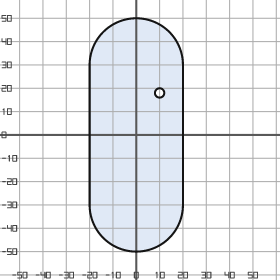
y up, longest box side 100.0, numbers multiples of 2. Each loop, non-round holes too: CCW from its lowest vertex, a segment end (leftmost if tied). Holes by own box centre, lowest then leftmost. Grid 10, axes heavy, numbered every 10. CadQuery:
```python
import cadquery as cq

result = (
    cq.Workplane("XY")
    .moveTo(-20.0, -30.0)
    .threePointArc((0.0, -50.0), (20.0, -30.0))
    .lineTo(20.0, 30.0)
    .threePointArc((0.0, 50.0), (-20.0, 30.0))
    .close()
    .moveTo(10.0, 18.0)
    .circle(2.0)
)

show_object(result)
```